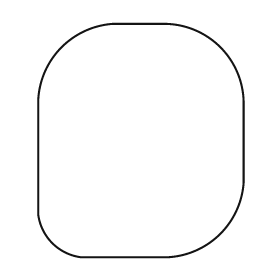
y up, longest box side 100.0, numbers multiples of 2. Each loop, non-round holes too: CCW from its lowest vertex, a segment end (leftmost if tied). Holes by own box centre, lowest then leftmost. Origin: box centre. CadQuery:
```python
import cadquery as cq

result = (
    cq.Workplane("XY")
    .moveTo(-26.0, -50.0)
    .lineTo(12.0, -50.0)
    .threePointArc((34.0, -40.0), (44.0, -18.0))
    .lineTo(44.0, 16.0)
    .threePointArc((34.0, 40.0), (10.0, 50.0))
    .lineTo(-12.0, 50.0)
    .threePointArc((-34.0, 40.0), (-44.0, 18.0))
    .lineTo(-44.0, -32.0)
    .threePointArc((-38.0, -44.0), (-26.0, -50.0))
    .close()
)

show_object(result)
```